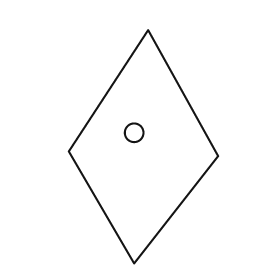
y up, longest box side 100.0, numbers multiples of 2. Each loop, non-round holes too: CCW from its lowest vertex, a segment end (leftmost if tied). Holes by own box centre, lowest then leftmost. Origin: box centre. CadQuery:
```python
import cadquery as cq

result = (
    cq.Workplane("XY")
    .moveTo(-4.0, -50.0)
    .lineTo(32.0, -4.0)
    .lineTo(2.0, 50.0)
    .lineTo(-32.0, -2.0)
    .close()
    .moveTo(-4.0, 6.0)
    .circle(4.0)
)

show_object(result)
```